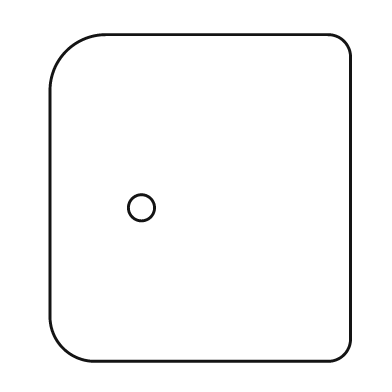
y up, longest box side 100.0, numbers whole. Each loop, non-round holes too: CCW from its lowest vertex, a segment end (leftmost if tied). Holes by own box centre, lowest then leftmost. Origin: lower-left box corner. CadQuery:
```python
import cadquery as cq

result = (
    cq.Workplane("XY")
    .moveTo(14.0, 0.0)
    .lineTo(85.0, 0.0)
    .threePointArc((90.0, 2.0), (92.0, 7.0))
    .lineTo(92.0, 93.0)
    .threePointArc((90.0, 98.0), (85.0, 100.0))
    .lineTo(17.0, 100.0)
    .threePointArc((5.0, 95.0), (0.0, 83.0))
    .lineTo(0.0, 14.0)
    .threePointArc((4.0, 4.0), (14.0, 0.0))
    .close()
    .moveTo(28.0, 47.0)
    .circle(4.0)
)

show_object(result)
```